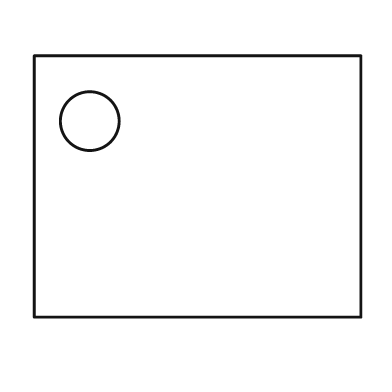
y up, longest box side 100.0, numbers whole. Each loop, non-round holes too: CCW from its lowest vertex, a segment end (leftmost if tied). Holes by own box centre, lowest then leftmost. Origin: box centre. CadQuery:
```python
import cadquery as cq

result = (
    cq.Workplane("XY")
    .moveTo(-50.0, -40.0)
    .lineTo(50.0, -40.0)
    .lineTo(50.0, 40.0)
    .lineTo(-50.0, 40.0)
    .close()
    .moveTo(-33.0, 20.0)
    .circle(9.0)
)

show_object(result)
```